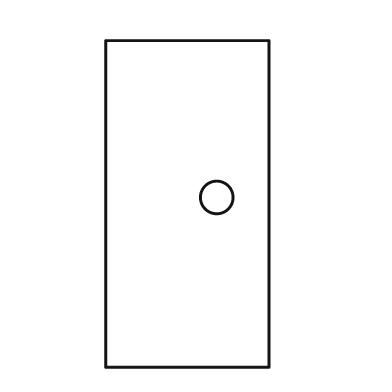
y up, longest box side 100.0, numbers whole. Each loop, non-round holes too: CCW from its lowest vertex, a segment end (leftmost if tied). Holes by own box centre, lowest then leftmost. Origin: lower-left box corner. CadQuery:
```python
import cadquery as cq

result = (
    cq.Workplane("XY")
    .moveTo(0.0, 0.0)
    .lineTo(50.0, 0.0)
    .lineTo(50.0, 100.0)
    .lineTo(0.0, 100.0)
    .close()
    .moveTo(34.0, 52.0)
    .circle(5.0)
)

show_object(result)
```